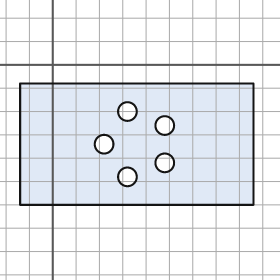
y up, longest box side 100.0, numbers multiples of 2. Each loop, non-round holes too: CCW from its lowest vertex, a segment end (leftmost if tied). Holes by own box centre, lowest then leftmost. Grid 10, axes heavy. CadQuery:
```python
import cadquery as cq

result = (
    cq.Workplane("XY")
    .moveTo(-14.0, -60.0)
    .lineTo(86.0, -60.0)
    .lineTo(86.0, -8.0)
    .lineTo(-14.0, -8.0)
    .close()
    .moveTo(32.0, -48.0)
    .circle(4.0)
    .moveTo(48.0, -42.0)
    .circle(4.0)
    .moveTo(22.0, -34.0)
    .circle(4.0)
    .moveTo(48.0, -26.0)
    .circle(4.0)
    .moveTo(32.0, -20.0)
    .circle(4.0)
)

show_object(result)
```